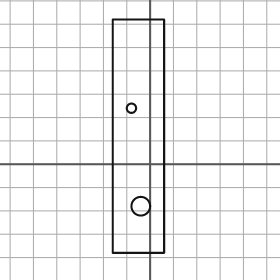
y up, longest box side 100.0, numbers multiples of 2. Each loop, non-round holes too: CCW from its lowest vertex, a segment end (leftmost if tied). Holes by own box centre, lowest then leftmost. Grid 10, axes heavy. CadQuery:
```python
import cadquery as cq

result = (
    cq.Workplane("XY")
    .moveTo(-16.0, -38.0)
    .lineTo(6.0, -38.0)
    .lineTo(6.0, 62.0)
    .lineTo(-16.0, 62.0)
    .close()
    .moveTo(-4.0, -18.0)
    .circle(4.0)
    .moveTo(-8.0, 24.0)
    .circle(2.0)
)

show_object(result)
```